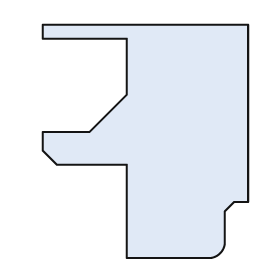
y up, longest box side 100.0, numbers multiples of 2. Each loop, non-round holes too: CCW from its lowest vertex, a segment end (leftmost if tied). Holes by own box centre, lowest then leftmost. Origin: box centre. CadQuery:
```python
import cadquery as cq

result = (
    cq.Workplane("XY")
    .moveTo(-8.0, -50.0)
    .lineTo(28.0, -50.0)
    .threePointArc((32.0, -48.0), (34.0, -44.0))
    .lineTo(34.0, -30.0)
    .lineTo(38.0, -26.0)
    .lineTo(44.0, -26.0)
    .lineTo(44.0, 50.0)
    .lineTo(-44.0, 50.0)
    .lineTo(-44.0, 44.0)
    .lineTo(-8.0, 44.0)
    .lineTo(-8.0, 20.0)
    .lineTo(-24.0, 4.0)
    .lineTo(-44.0, 4.0)
    .lineTo(-44.0, -4.0)
    .lineTo(-38.0, -10.0)
    .lineTo(-8.0, -10.0)
    .close()
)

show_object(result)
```